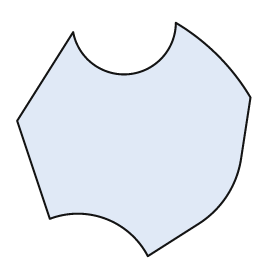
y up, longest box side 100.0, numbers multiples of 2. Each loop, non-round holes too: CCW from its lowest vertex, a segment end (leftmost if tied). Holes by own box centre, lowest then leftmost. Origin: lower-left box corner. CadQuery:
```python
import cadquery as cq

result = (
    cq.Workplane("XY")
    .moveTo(56.0, 0.0)
    .lineTo(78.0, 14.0)
    .threePointArc((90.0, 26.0), (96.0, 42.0))
    .lineTo(100.0, 68.0)
    .threePointArc((86.0, 86.0), (68.0, 100.0))
    .threePointArc((48.0, 78.0), (24.0, 96.0))
    .lineTo(0.0, 58.0)
    .lineTo(14.0, 16.0)
    .threePointArc((38.0, 16.0), (56.0, 0.0))
    .close()
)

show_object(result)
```